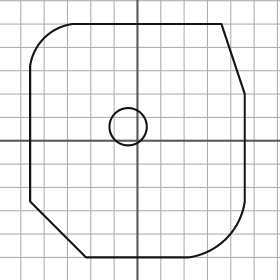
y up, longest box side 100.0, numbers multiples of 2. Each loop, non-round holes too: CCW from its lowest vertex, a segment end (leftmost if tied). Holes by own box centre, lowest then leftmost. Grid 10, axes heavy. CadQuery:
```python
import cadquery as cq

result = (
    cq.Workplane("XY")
    .moveTo(-22.0, -50.0)
    .lineTo(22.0, -50.0)
    .threePointArc((38.0, -42.0), (46.0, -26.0))
    .lineTo(46.0, 20.0)
    .lineTo(36.0, 50.0)
    .lineTo(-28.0, 50.0)
    .threePointArc((-40.0, 44.0), (-46.0, 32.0))
    .lineTo(-46.0, -26.0)
    .close()
    .moveTo(-4.0, 6.0)
    .circle(8.0)
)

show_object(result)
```